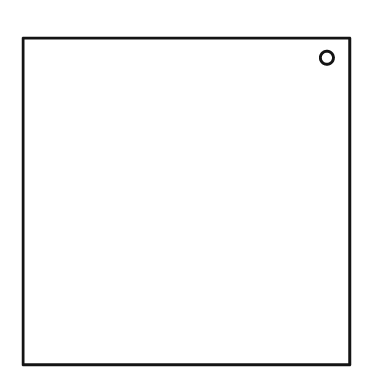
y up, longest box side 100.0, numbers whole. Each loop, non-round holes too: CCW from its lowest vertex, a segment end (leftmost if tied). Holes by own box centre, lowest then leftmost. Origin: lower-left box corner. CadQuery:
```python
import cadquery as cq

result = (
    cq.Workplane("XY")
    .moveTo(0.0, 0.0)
    .lineTo(100.0, 0.0)
    .lineTo(100.0, 100.0)
    .lineTo(0.0, 100.0)
    .close()
    .moveTo(93.0, 94.0)
    .circle(2.0)
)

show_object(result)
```